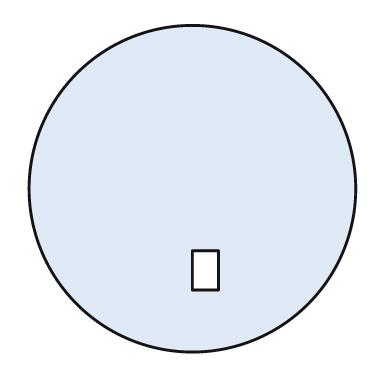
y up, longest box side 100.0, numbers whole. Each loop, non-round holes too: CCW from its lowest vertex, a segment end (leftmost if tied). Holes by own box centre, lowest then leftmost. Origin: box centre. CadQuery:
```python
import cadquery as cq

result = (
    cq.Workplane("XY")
    .moveTo(0.0, 0.0)
    .circle(50.0)
    .moveTo(0.0, -31.0)
    .lineTo(8.0, -31.0)
    .lineTo(8.0, -19.0)
    .lineTo(0.0, -19.0)
    .close()
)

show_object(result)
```